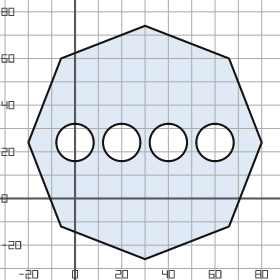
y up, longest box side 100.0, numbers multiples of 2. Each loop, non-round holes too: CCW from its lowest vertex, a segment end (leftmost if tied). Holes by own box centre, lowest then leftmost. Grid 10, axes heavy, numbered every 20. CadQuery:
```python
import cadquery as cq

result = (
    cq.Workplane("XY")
    .moveTo(30.0, -26.0)
    .lineTo(66.0, -12.0)
    .lineTo(80.0, 24.0)
    .lineTo(66.0, 60.0)
    .lineTo(30.0, 74.0)
    .lineTo(-6.0, 60.0)
    .lineTo(-20.0, 24.0)
    .lineTo(-6.0, -12.0)
    .close()
    .moveTo(0.0, 24.0)
    .circle(8.0)
    .moveTo(20.0, 24.0)
    .circle(8.0)
    .moveTo(40.0, 24.0)
    .circle(8.0)
    .moveTo(60.0, 24.0)
    .circle(8.0)
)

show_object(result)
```